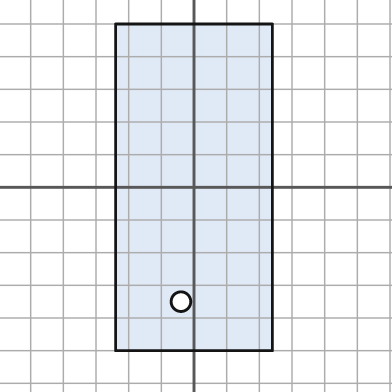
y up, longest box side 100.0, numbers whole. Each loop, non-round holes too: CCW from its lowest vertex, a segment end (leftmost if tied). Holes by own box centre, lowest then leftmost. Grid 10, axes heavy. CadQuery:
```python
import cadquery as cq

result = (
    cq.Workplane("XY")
    .moveTo(-24.0, -50.0)
    .lineTo(24.0, -50.0)
    .lineTo(24.0, 50.0)
    .lineTo(-24.0, 50.0)
    .close()
    .moveTo(-4.0, -35.0)
    .circle(3.0)
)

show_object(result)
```